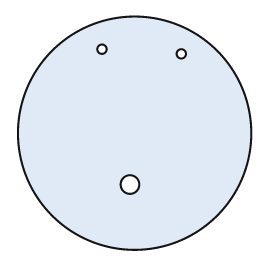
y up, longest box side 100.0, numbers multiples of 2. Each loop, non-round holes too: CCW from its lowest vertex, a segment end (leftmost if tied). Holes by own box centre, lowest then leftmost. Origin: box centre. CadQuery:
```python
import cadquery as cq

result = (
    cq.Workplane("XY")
    .moveTo(0.0, 0.0)
    .circle(50.0)
    .moveTo(-2.0, -22.0)
    .circle(4.0)
    .moveTo(20.0, 34.0)
    .circle(2.0)
    .moveTo(-14.0, 36.0)
    .circle(2.0)
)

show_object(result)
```